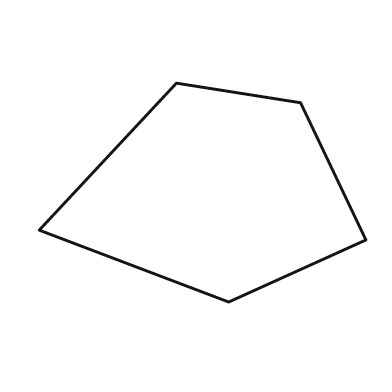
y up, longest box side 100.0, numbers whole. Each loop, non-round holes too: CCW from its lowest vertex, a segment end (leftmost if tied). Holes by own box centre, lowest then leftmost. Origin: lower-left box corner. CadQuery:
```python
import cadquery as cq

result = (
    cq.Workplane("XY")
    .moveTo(58.0, 0.0)
    .lineTo(100.0, 19.0)
    .lineTo(80.0, 61.0)
    .lineTo(42.0, 67.0)
    .lineTo(0.0, 22.0)
    .close()
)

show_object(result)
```